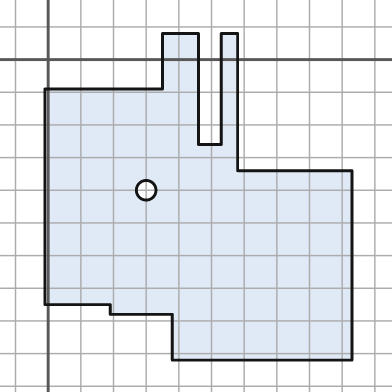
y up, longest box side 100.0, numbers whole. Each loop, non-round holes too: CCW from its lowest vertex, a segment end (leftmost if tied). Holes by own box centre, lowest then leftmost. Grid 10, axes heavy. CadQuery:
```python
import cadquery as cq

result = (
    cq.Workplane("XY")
    .moveTo(38.0, -92.0)
    .lineTo(93.0, -92.0)
    .lineTo(93.0, -34.0)
    .lineTo(58.0, -34.0)
    .lineTo(58.0, 8.0)
    .lineTo(53.0, 8.0)
    .lineTo(53.0, -26.0)
    .lineTo(46.0, -26.0)
    .lineTo(46.0, 8.0)
    .lineTo(35.0, 8.0)
    .lineTo(35.0, -9.0)
    .lineTo(-1.0, -9.0)
    .lineTo(-1.0, -75.0)
    .lineTo(19.0, -75.0)
    .lineTo(19.0, -78.0)
    .lineTo(38.0, -78.0)
    .close()
    .moveTo(30.0, -40.0)
    .circle(3.0)
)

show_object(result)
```